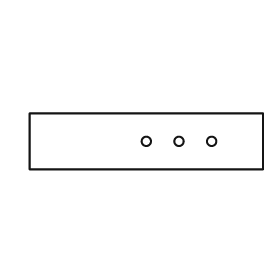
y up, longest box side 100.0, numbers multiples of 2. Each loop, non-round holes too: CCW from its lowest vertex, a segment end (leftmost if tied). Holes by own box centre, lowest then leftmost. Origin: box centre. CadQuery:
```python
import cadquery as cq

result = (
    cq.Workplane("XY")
    .moveTo(-50.0, -12.0)
    .lineTo(50.0, -12.0)
    .lineTo(50.0, 12.0)
    .lineTo(-50.0, 12.0)
    .close()
    .moveTo(0.0, 0.0)
    .circle(2.0)
    .moveTo(14.0, 0.0)
    .circle(2.0)
    .moveTo(28.0, 0.0)
    .circle(2.0)
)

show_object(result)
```